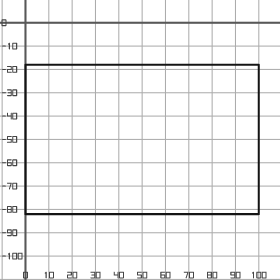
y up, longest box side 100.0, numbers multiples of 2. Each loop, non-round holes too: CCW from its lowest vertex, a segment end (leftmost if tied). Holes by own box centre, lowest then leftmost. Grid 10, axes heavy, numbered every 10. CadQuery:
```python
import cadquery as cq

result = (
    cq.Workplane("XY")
    .moveTo(0.0, -82.0)
    .lineTo(100.0, -82.0)
    .lineTo(100.0, -18.0)
    .lineTo(0.0, -18.0)
    .close()
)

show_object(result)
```